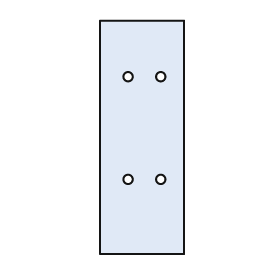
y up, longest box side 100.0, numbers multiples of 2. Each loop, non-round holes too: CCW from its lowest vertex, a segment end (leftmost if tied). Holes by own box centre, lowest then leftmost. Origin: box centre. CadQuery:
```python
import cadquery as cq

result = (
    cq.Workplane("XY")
    .moveTo(-18.0, -50.0)
    .lineTo(18.0, -50.0)
    .lineTo(18.0, 50.0)
    .lineTo(-18.0, 50.0)
    .close()
    .moveTo(-6.0, -18.0)
    .circle(2.0)
    .moveTo(8.0, -18.0)
    .circle(2.0)
    .moveTo(-6.0, 26.0)
    .circle(2.0)
    .moveTo(8.0, 26.0)
    .circle(2.0)
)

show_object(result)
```